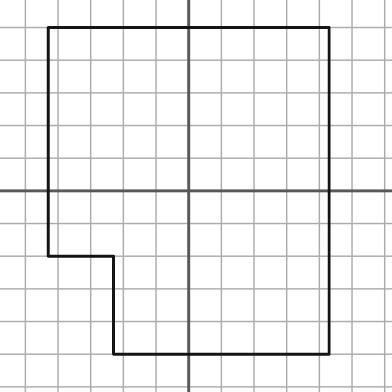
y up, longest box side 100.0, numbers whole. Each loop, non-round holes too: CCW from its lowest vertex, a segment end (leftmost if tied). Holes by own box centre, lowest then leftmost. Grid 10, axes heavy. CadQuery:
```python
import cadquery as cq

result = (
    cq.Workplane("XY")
    .moveTo(-23.0, -50.0)
    .lineTo(43.0, -50.0)
    .lineTo(43.0, 50.0)
    .lineTo(-43.0, 50.0)
    .lineTo(-43.0, -20.0)
    .lineTo(-23.0, -20.0)
    .close()
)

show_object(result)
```